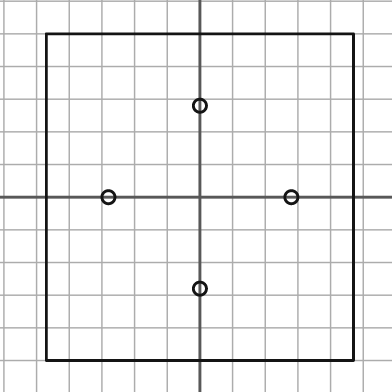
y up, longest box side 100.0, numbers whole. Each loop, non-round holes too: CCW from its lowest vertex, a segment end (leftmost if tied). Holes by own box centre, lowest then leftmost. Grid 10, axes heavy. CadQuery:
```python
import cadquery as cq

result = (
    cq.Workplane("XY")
    .moveTo(-47.0, -50.0)
    .lineTo(47.0, -50.0)
    .lineTo(47.0, 50.0)
    .lineTo(-47.0, 50.0)
    .close()
    .moveTo(0.0, -28.0)
    .circle(2.0)
    .moveTo(-28.0, 0.0)
    .circle(2.0)
    .moveTo(28.0, 0.0)
    .circle(2.0)
    .moveTo(0.0, 28.0)
    .circle(2.0)
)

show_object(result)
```